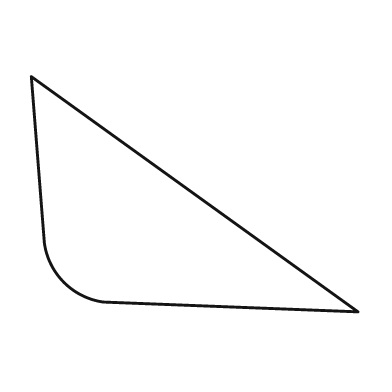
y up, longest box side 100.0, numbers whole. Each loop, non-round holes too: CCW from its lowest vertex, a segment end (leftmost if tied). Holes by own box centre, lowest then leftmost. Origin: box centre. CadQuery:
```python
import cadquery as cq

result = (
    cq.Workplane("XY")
    .moveTo(50.0, -36.0)
    .lineTo(-50.0, 36.0)
    .lineTo(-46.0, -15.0)
    .threePointArc((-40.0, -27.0), (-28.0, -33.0))
    .close()
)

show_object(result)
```